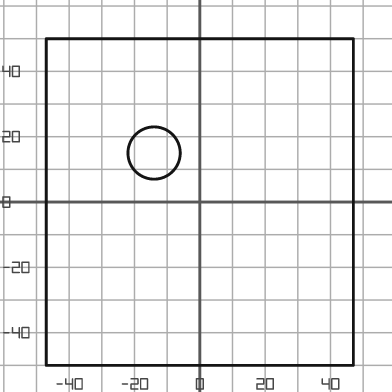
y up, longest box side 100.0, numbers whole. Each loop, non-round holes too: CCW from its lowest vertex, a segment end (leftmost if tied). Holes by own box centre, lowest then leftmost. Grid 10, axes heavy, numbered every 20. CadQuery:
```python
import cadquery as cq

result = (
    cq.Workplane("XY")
    .moveTo(-47.0, -50.0)
    .lineTo(47.0, -50.0)
    .lineTo(47.0, 50.0)
    .lineTo(-47.0, 50.0)
    .close()
    .moveTo(-14.0, 15.0)
    .circle(8.0)
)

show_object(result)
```